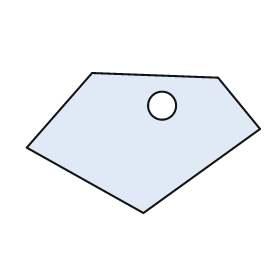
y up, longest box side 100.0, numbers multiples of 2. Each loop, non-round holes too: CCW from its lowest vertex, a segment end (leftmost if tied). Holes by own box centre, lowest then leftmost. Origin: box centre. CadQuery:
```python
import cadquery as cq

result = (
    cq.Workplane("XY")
    .moveTo(0.0, -30.0)
    .lineTo(50.0, 6.0)
    .lineTo(32.0, 28.0)
    .lineTo(-22.0, 30.0)
    .lineTo(-50.0, -2.0)
    .close()
    .moveTo(8.0, 16.0)
    .circle(6.0)
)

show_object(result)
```